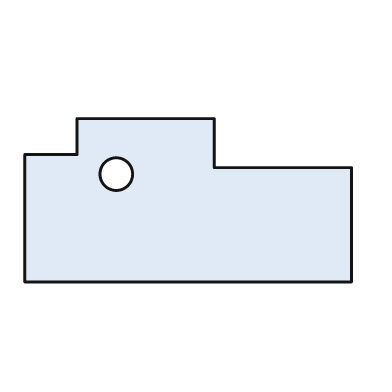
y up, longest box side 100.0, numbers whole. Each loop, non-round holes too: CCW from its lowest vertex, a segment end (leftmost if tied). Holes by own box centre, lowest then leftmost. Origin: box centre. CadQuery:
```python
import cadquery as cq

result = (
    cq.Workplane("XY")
    .moveTo(-50.0, -25.0)
    .lineTo(50.0, -25.0)
    .lineTo(50.0, 10.0)
    .lineTo(8.0, 10.0)
    .lineTo(8.0, 25.0)
    .lineTo(-34.0, 25.0)
    .lineTo(-34.0, 14.0)
    .lineTo(-50.0, 14.0)
    .close()
    .moveTo(-22.0, 8.0)
    .circle(5.0)
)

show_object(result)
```